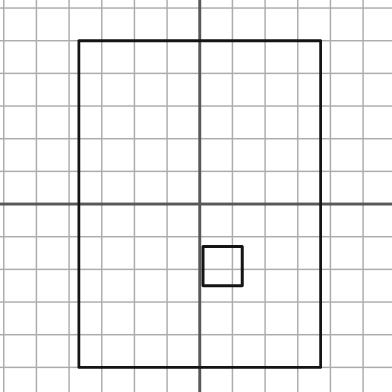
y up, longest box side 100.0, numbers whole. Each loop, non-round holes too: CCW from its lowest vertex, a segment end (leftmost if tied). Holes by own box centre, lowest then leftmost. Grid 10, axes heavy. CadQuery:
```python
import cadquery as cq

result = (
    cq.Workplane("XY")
    .moveTo(-37.0, -50.0)
    .lineTo(37.0, -50.0)
    .lineTo(37.0, 50.0)
    .lineTo(-37.0, 50.0)
    .close()
    .moveTo(1.0, -25.0)
    .lineTo(13.0, -25.0)
    .lineTo(13.0, -13.0)
    .lineTo(1.0, -13.0)
    .close()
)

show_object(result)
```